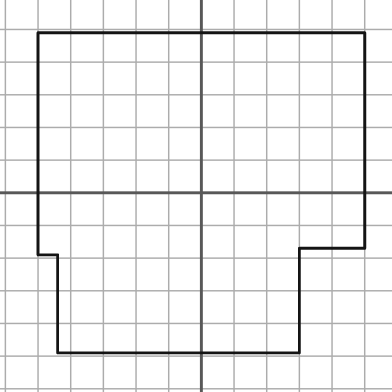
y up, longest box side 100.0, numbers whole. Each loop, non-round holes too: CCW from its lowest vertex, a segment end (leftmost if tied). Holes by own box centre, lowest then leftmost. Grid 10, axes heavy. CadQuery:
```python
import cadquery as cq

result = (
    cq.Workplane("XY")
    .moveTo(-44.0, -49.0)
    .lineTo(30.0, -49.0)
    .lineTo(30.0, -17.0)
    .lineTo(50.0, -17.0)
    .lineTo(50.0, 49.0)
    .lineTo(-50.0, 49.0)
    .lineTo(-50.0, -19.0)
    .lineTo(-44.0, -19.0)
    .close()
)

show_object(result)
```